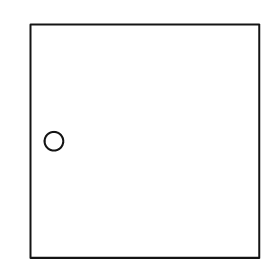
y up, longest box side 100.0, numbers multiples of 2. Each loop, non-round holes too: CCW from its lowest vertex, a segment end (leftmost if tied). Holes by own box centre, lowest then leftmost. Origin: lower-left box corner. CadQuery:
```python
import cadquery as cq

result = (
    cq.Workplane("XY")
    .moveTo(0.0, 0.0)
    .lineTo(98.0, 0.0)
    .lineTo(98.0, 100.0)
    .lineTo(0.0, 100.0)
    .close()
    .moveTo(10.0, 50.0)
    .circle(4.0)
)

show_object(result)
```